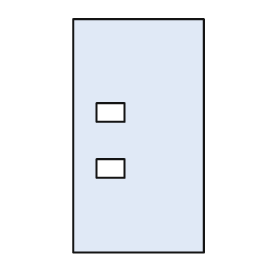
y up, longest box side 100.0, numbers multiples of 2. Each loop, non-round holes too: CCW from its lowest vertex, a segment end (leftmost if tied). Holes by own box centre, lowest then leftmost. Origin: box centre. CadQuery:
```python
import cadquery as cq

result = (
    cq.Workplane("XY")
    .moveTo(-28.0, -50.0)
    .lineTo(28.0, -50.0)
    .lineTo(28.0, 50.0)
    .lineTo(-28.0, 50.0)
    .close()
    .moveTo(-18.0, -18.0)
    .lineTo(-6.0, -18.0)
    .lineTo(-6.0, -10.0)
    .lineTo(-18.0, -10.0)
    .close()
    .moveTo(-18.0, 6.0)
    .lineTo(-6.0, 6.0)
    .lineTo(-6.0, 14.0)
    .lineTo(-18.0, 14.0)
    .close()
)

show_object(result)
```